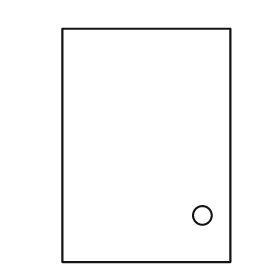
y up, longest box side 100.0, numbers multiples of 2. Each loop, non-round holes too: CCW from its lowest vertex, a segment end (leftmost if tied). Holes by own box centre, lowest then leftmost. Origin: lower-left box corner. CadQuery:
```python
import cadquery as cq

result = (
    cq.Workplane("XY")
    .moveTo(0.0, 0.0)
    .lineTo(72.0, 0.0)
    .lineTo(72.0, 100.0)
    .lineTo(0.0, 100.0)
    .close()
    .moveTo(60.0, 20.0)
    .circle(4.0)
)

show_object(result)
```